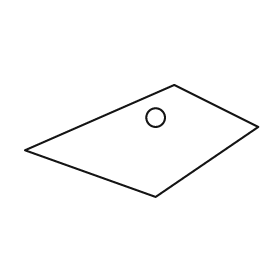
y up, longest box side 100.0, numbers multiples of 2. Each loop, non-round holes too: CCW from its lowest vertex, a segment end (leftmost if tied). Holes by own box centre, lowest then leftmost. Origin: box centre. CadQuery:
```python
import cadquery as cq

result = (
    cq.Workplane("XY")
    .moveTo(6.0, -24.0)
    .lineTo(50.0, 6.0)
    .lineTo(14.0, 24.0)
    .lineTo(-50.0, -4.0)
    .close()
    .moveTo(6.0, 10.0)
    .circle(4.0)
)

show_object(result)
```